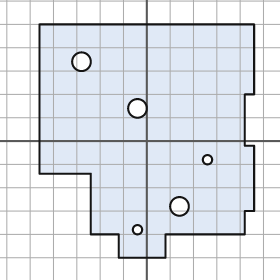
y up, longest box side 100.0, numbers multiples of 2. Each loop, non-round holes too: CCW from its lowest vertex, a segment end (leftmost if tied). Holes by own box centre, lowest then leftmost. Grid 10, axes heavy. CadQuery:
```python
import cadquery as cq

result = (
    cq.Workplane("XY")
    .moveTo(-12.0, -50.0)
    .lineTo(8.0, -50.0)
    .lineTo(8.0, -40.0)
    .lineTo(42.0, -40.0)
    .lineTo(42.0, -30.0)
    .lineTo(46.0, -30.0)
    .lineTo(46.0, -2.0)
    .lineTo(42.0, -2.0)
    .lineTo(42.0, 20.0)
    .lineTo(46.0, 20.0)
    .lineTo(46.0, 50.0)
    .lineTo(-46.0, 50.0)
    .lineTo(-46.0, -14.0)
    .lineTo(-24.0, -14.0)
    .lineTo(-24.0, -40.0)
    .lineTo(-12.0, -40.0)
    .close()
    .moveTo(-4.0, -38.0)
    .circle(2.0)
    .moveTo(14.0, -28.0)
    .circle(4.0)
    .moveTo(26.0, -8.0)
    .circle(2.0)
    .moveTo(-4.0, 14.0)
    .circle(4.0)
    .moveTo(-28.0, 34.0)
    .circle(4.0)
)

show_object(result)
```